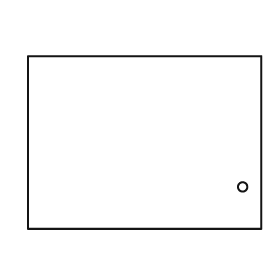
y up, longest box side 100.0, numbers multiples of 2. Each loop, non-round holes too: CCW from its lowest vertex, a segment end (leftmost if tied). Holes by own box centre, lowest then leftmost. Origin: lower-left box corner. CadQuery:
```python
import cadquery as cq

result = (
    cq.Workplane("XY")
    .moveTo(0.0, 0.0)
    .lineTo(100.0, 0.0)
    .lineTo(100.0, 74.0)
    .lineTo(0.0, 74.0)
    .close()
    .moveTo(92.0, 18.0)
    .circle(2.0)
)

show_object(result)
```